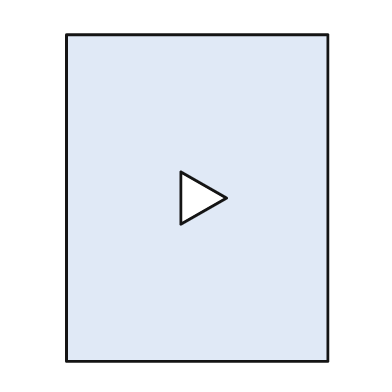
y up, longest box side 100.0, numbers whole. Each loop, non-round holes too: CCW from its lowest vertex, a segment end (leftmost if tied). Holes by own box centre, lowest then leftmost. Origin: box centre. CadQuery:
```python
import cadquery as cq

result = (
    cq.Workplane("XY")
    .moveTo(-40.0, -50.0)
    .lineTo(40.0, -50.0)
    .lineTo(40.0, 50.0)
    .lineTo(-40.0, 50.0)
    .close()
    .moveTo(-5.0, -8.0)
    .lineTo(9.0, 0.0)
    .lineTo(-5.0, 8.0)
    .close()
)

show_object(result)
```